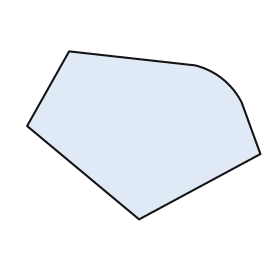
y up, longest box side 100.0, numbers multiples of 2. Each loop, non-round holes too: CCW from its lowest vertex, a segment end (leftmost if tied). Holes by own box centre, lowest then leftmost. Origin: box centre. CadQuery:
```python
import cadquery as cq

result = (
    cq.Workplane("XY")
    .moveTo(-2.0, -36.0)
    .lineTo(50.0, -8.0)
    .lineTo(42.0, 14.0)
    .threePointArc((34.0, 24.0), (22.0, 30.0))
    .lineTo(-32.0, 36.0)
    .lineTo(-50.0, 4.0)
    .close()
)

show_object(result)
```